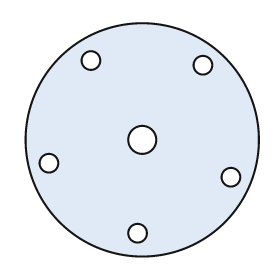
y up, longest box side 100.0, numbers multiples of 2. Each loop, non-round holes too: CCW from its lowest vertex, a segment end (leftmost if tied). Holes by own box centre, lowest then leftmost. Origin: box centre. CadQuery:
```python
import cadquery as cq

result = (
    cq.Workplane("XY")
    .moveTo(0.0, 0.0)
    .circle(50.0)
    .moveTo(-2.0, -40.0)
    .circle(4.0)
    .moveTo(38.0, -16.0)
    .circle(4.0)
    .moveTo(-40.0, -10.0)
    .circle(4.0)
    .moveTo(0.0, 0.0)
    .circle(6.0)
    .moveTo(26.0, 32.0)
    .circle(4.0)
    .moveTo(-22.0, 34.0)
    .circle(4.0)
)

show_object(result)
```